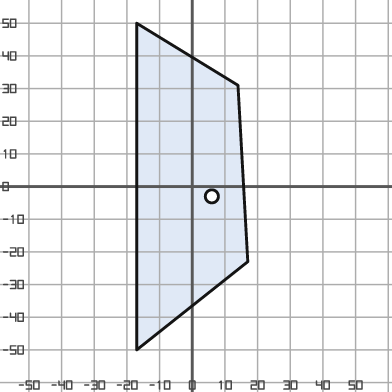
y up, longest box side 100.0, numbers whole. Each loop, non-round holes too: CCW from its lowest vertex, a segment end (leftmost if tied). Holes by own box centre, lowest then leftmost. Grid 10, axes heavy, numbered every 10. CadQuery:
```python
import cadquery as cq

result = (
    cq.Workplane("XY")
    .moveTo(-17.0, -50.0)
    .lineTo(17.0, -23.0)
    .lineTo(14.0, 31.0)
    .lineTo(-17.0, 50.0)
    .close()
    .moveTo(6.0, -3.0)
    .circle(2.0)
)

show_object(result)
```